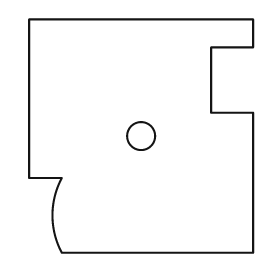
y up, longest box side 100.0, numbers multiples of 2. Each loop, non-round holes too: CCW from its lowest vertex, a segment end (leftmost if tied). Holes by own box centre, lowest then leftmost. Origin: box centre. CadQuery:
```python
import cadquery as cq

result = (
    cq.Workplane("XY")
    .moveTo(-34.0, -50.0)
    .lineTo(48.0, -50.0)
    .lineTo(48.0, 10.0)
    .lineTo(30.0, 10.0)
    .lineTo(30.0, 38.0)
    .lineTo(48.0, 38.0)
    .lineTo(48.0, 50.0)
    .lineTo(-48.0, 50.0)
    .lineTo(-48.0, -18.0)
    .lineTo(-34.0, -18.0)
    .threePointArc((-38.0, -34.0), (-34.0, -50.0))
    .close()
    .moveTo(0.0, 0.0)
    .circle(6.0)
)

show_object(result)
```